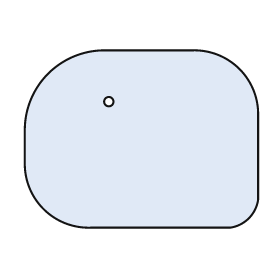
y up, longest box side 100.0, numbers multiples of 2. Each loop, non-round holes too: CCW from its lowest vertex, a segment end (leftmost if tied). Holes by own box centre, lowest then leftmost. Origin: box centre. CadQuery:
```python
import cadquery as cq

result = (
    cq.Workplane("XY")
    .moveTo(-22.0, -38.0)
    .lineTo(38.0, -38.0)
    .threePointArc((46.0, -34.0), (50.0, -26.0))
    .lineTo(50.0, 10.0)
    .threePointArc((42.0, 30.0), (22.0, 38.0))
    .lineTo(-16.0, 38.0)
    .threePointArc((-40.0, 28.0), (-50.0, 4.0))
    .lineTo(-50.0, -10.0)
    .threePointArc((-42.0, -30.0), (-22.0, -38.0))
    .close()
    .moveTo(-14.0, 16.0)
    .circle(2.0)
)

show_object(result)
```